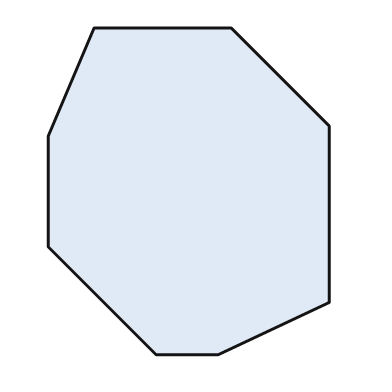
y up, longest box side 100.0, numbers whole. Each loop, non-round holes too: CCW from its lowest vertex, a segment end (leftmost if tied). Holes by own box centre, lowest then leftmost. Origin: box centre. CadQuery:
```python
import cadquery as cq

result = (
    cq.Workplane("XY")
    .moveTo(-10.0, -50.0)
    .lineTo(9.0, -50.0)
    .lineTo(43.0, -34.0)
    .lineTo(43.0, 20.0)
    .lineTo(13.0, 50.0)
    .lineTo(-29.0, 50.0)
    .lineTo(-43.0, 17.0)
    .lineTo(-43.0, -17.0)
    .close()
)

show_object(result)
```